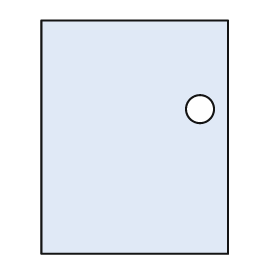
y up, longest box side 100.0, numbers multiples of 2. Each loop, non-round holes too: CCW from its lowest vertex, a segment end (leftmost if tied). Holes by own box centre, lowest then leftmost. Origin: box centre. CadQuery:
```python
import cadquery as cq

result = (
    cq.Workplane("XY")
    .moveTo(-40.0, -50.0)
    .lineTo(40.0, -50.0)
    .lineTo(40.0, 50.0)
    .lineTo(-40.0, 50.0)
    .close()
    .moveTo(28.0, 12.0)
    .circle(6.0)
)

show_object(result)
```